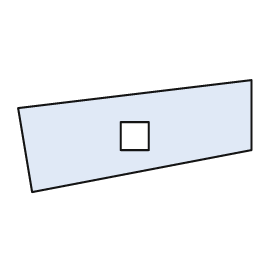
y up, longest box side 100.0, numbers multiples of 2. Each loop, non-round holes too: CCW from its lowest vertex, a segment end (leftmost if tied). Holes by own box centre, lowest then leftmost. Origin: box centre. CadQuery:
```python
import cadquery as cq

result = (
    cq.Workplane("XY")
    .moveTo(-44.0, -24.0)
    .lineTo(50.0, -6.0)
    .lineTo(50.0, 24.0)
    .lineTo(-50.0, 12.0)
    .close()
    .moveTo(-6.0, -6.0)
    .lineTo(6.0, -6.0)
    .lineTo(6.0, 6.0)
    .lineTo(-6.0, 6.0)
    .close()
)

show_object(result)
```